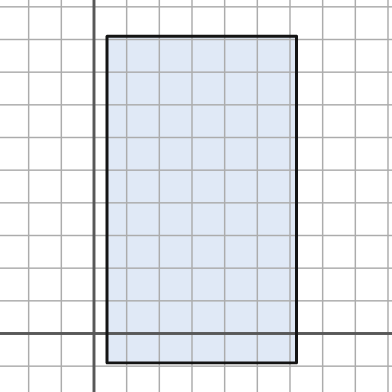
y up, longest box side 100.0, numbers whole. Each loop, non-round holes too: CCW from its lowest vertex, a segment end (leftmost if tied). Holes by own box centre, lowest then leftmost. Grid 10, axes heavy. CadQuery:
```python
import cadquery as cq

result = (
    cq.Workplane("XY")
    .moveTo(4.0, -9.0)
    .lineTo(62.0, -9.0)
    .lineTo(62.0, 91.0)
    .lineTo(4.0, 91.0)
    .close()
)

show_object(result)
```